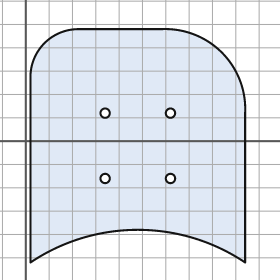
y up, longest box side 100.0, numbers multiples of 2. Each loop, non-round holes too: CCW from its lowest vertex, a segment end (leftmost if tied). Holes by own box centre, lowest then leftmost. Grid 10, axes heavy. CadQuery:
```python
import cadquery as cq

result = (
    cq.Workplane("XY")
    .moveTo(2.0, -52.0)
    .threePointArc((48.0, -38.0), (94.0, -52.0))
    .lineTo(94.0, 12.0)
    .threePointArc((84.0, 38.0), (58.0, 48.0))
    .lineTo(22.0, 48.0)
    .threePointArc((8.0, 42.0), (2.0, 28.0))
    .close()
    .moveTo(34.0, -16.0)
    .circle(2.0)
    .moveTo(62.0, -16.0)
    .circle(2.0)
    .moveTo(34.0, 12.0)
    .circle(2.0)
    .moveTo(62.0, 12.0)
    .circle(2.0)
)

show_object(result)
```